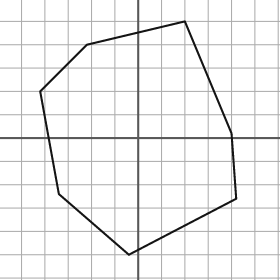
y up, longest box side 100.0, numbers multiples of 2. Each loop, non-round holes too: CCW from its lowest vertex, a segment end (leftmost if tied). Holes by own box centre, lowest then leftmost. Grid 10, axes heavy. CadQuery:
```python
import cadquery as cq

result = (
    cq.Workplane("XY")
    .moveTo(-4.0, -50.0)
    .lineTo(42.0, -26.0)
    .lineTo(40.0, 2.0)
    .lineTo(20.0, 50.0)
    .lineTo(-22.0, 40.0)
    .lineTo(-42.0, 20.0)
    .lineTo(-34.0, -24.0)
    .close()
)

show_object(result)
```